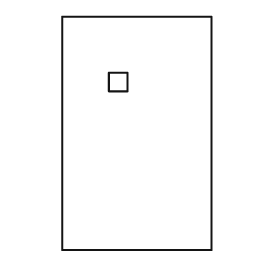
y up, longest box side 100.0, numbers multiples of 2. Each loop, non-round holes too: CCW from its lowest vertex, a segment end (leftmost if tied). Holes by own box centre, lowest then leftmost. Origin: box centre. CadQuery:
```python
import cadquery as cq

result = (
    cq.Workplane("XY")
    .moveTo(-32.0, -50.0)
    .lineTo(32.0, -50.0)
    .lineTo(32.0, 50.0)
    .lineTo(-32.0, 50.0)
    .close()
    .moveTo(-12.0, 18.0)
    .lineTo(-4.0, 18.0)
    .lineTo(-4.0, 26.0)
    .lineTo(-12.0, 26.0)
    .close()
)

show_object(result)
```